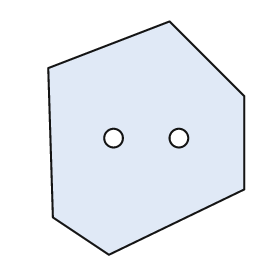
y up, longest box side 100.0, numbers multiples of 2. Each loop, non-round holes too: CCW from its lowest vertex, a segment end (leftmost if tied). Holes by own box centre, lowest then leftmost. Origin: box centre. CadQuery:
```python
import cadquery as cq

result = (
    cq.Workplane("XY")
    .moveTo(-16.0, -50.0)
    .lineTo(42.0, -22.0)
    .lineTo(42.0, 18.0)
    .lineTo(10.0, 50.0)
    .lineTo(-42.0, 30.0)
    .lineTo(-40.0, -34.0)
    .close()
    .moveTo(-14.0, 0.0)
    .circle(4.0)
    .moveTo(14.0, 0.0)
    .circle(4.0)
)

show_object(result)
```